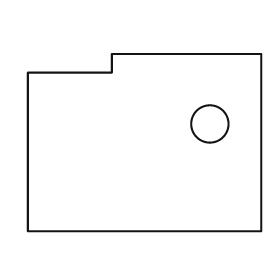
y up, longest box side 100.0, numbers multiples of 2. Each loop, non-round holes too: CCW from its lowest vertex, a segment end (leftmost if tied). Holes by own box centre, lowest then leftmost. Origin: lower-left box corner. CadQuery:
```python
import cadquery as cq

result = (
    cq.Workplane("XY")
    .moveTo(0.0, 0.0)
    .lineTo(100.0, 0.0)
    .lineTo(100.0, 76.0)
    .lineTo(36.0, 76.0)
    .lineTo(36.0, 68.0)
    .lineTo(0.0, 68.0)
    .close()
    .moveTo(78.0, 46.0)
    .circle(8.0)
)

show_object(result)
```